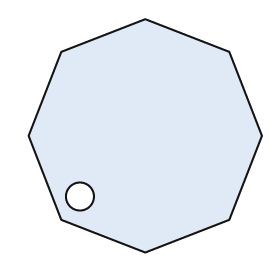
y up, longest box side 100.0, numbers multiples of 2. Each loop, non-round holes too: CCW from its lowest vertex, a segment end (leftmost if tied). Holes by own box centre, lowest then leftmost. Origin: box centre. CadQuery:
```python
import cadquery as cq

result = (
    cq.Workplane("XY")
    .moveTo(0.0, -50.0)
    .lineTo(36.0, -36.0)
    .lineTo(50.0, 0.0)
    .lineTo(36.0, 36.0)
    .lineTo(0.0, 50.0)
    .lineTo(-36.0, 36.0)
    .lineTo(-50.0, 0.0)
    .lineTo(-36.0, -36.0)
    .close()
    .moveTo(-28.0, -26.0)
    .circle(6.0)
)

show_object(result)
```